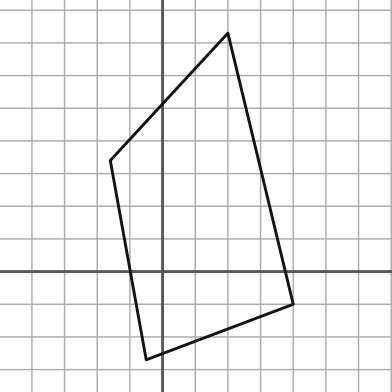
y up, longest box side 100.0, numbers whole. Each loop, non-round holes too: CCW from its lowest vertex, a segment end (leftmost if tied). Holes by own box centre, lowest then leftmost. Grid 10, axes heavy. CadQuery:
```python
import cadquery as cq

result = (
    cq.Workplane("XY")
    .moveTo(-5.0, -27.0)
    .lineTo(40.0, -10.0)
    .lineTo(20.0, 73.0)
    .lineTo(-16.0, 34.0)
    .close()
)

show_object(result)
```